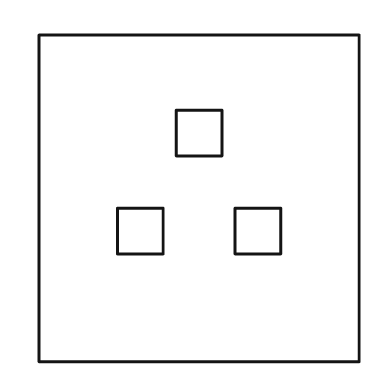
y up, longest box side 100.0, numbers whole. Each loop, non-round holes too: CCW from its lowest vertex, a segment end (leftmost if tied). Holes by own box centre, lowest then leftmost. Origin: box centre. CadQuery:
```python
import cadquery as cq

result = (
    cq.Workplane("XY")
    .moveTo(-49.0, -50.0)
    .lineTo(49.0, -50.0)
    .lineTo(49.0, 50.0)
    .lineTo(-49.0, 50.0)
    .close()
    .moveTo(-25.0, -17.0)
    .lineTo(-11.0, -17.0)
    .lineTo(-11.0, -3.0)
    .lineTo(-25.0, -3.0)
    .close()
    .moveTo(11.0, -17.0)
    .lineTo(25.0, -17.0)
    .lineTo(25.0, -3.0)
    .lineTo(11.0, -3.0)
    .close()
    .moveTo(-7.0, 13.0)
    .lineTo(7.0, 13.0)
    .lineTo(7.0, 27.0)
    .lineTo(-7.0, 27.0)
    .close()
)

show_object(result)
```